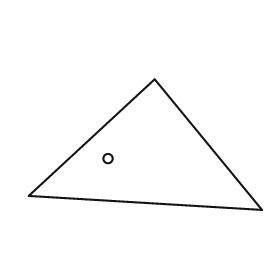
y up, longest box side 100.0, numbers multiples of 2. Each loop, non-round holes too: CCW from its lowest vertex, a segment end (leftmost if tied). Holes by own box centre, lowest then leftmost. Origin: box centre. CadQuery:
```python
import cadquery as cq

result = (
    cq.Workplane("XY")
    .moveTo(50.0, -28.0)
    .lineTo(4.0, 28.0)
    .lineTo(-50.0, -22.0)
    .close()
    .moveTo(-16.0, -6.0)
    .circle(2.0)
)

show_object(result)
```